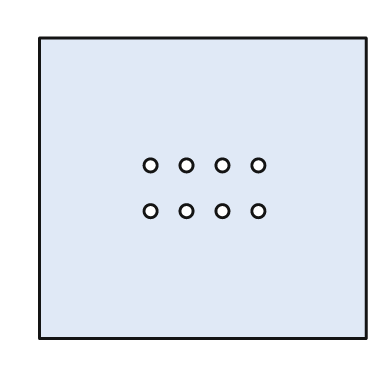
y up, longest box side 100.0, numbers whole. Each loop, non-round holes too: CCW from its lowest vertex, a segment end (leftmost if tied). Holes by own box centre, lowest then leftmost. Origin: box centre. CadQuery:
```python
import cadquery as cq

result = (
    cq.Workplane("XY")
    .moveTo(-50.0, -46.0)
    .lineTo(50.0, -46.0)
    .lineTo(50.0, 46.0)
    .lineTo(-50.0, 46.0)
    .close()
    .moveTo(-16.0, -7.0)
    .circle(2.0)
    .moveTo(-5.0, -7.0)
    .circle(2.0)
    .moveTo(6.0, -7.0)
    .circle(2.0)
    .moveTo(17.0, -7.0)
    .circle(2.0)
    .moveTo(-16.0, 7.0)
    .circle(2.0)
    .moveTo(-5.0, 7.0)
    .circle(2.0)
    .moveTo(6.0, 7.0)
    .circle(2.0)
    .moveTo(17.0, 7.0)
    .circle(2.0)
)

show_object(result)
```